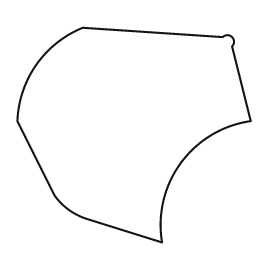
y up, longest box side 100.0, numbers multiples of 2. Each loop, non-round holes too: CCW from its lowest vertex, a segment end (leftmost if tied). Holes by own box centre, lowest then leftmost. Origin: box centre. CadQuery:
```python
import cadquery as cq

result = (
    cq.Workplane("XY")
    .moveTo(12.0, -46.0)
    .threePointArc((20.0, -12.0), (50.0, 6.0))
    .lineTo(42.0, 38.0)
    .threePointArc((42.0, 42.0), (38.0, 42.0))
    .lineTo(-22.0, 46.0)
    .threePointArc((-42.0, 30.0), (-50.0, 6.0))
    .lineTo(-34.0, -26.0)
    .threePointArc((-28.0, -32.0), (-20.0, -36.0))
    .close()
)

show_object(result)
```